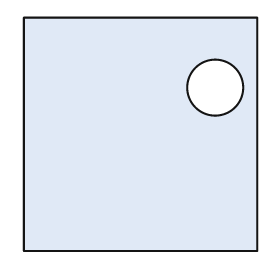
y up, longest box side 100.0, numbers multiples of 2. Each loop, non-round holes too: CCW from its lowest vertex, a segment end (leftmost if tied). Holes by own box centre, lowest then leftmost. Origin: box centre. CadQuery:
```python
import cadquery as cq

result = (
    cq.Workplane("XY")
    .moveTo(-50.0, -50.0)
    .lineTo(50.0, -50.0)
    .lineTo(50.0, 50.0)
    .lineTo(-50.0, 50.0)
    .close()
    .moveTo(32.0, 20.0)
    .circle(12.0)
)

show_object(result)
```